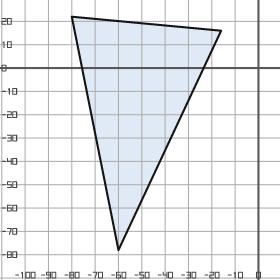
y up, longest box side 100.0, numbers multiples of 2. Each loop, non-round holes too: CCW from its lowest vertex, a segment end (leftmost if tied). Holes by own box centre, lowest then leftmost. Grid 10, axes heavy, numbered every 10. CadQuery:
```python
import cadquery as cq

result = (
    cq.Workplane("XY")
    .moveTo(-60.0, -78.0)
    .lineTo(-16.0, 16.0)
    .lineTo(-80.0, 22.0)
    .close()
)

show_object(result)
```